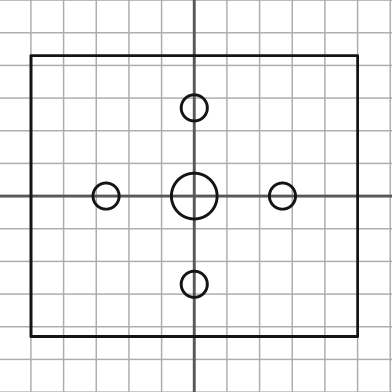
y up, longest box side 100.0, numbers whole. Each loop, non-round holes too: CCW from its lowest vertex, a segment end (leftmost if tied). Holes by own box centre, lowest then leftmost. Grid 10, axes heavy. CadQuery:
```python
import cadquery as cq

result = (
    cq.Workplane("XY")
    .moveTo(-50.0, -43.0)
    .lineTo(50.0, -43.0)
    .lineTo(50.0, 43.0)
    .lineTo(-50.0, 43.0)
    .close()
    .moveTo(0.0, -27.0)
    .circle(4.0)
    .moveTo(-27.0, 0.0)
    .circle(4.0)
    .moveTo(0.0, 0.0)
    .circle(7.0)
    .moveTo(27.0, 0.0)
    .circle(4.0)
    .moveTo(0.0, 27.0)
    .circle(4.0)
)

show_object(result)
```